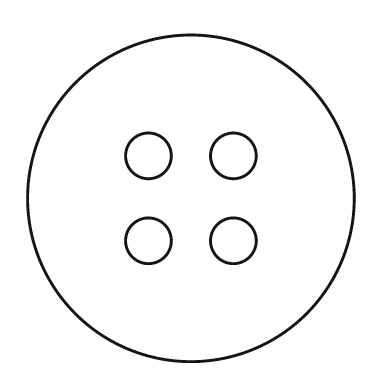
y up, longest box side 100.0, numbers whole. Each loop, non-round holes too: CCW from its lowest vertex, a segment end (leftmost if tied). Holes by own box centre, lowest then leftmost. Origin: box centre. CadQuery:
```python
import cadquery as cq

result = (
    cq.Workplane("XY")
    .moveTo(0.0, 0.0)
    .circle(50.0)
    .moveTo(-13.0, -13.0)
    .circle(7.0)
    .moveTo(13.0, -13.0)
    .circle(7.0)
    .moveTo(-13.0, 13.0)
    .circle(7.0)
    .moveTo(13.0, 13.0)
    .circle(7.0)
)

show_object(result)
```